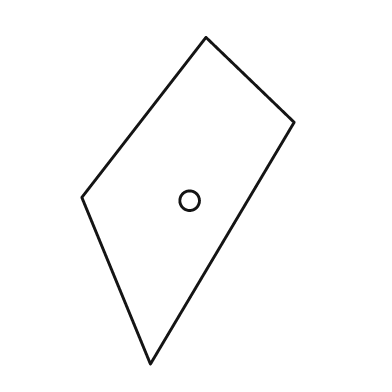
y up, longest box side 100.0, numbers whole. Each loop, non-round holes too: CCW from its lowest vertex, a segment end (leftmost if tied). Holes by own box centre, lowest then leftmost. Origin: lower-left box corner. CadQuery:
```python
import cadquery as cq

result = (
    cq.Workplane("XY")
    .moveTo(21.0, 0.0)
    .lineTo(65.0, 74.0)
    .lineTo(38.0, 100.0)
    .lineTo(0.0, 51.0)
    .close()
    .moveTo(33.0, 50.0)
    .circle(3.0)
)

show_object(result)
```